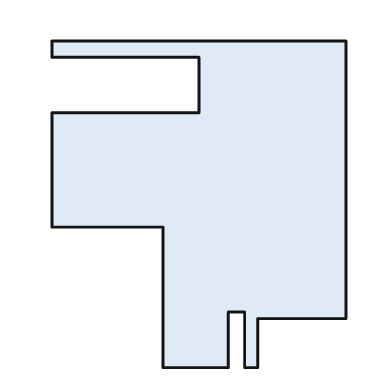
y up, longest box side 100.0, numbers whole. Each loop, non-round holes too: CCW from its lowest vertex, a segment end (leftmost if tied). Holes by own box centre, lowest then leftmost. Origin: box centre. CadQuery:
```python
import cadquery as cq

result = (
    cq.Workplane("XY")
    .moveTo(-11.0, -50.0)
    .lineTo(9.0, -50.0)
    .lineTo(9.0, -33.0)
    .lineTo(14.0, -33.0)
    .lineTo(14.0, -50.0)
    .lineTo(18.0, -50.0)
    .lineTo(18.0, -35.0)
    .lineTo(45.0, -35.0)
    .lineTo(45.0, 50.0)
    .lineTo(-45.0, 50.0)
    .lineTo(-45.0, 45.0)
    .lineTo(0.0, 45.0)
    .lineTo(0.0, 28.0)
    .lineTo(-45.0, 28.0)
    .lineTo(-45.0, -7.0)
    .lineTo(-11.0, -7.0)
    .close()
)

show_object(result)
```